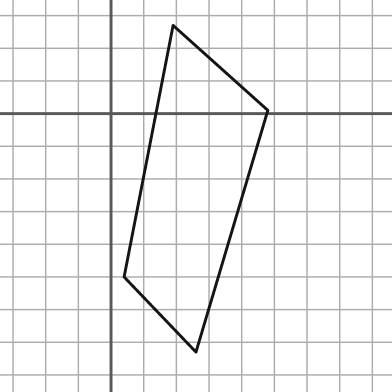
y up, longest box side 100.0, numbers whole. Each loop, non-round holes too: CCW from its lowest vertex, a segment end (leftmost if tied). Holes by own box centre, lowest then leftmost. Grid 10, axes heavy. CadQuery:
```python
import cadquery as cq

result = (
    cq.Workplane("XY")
    .moveTo(26.0, -73.0)
    .lineTo(48.0, 1.0)
    .lineTo(19.0, 27.0)
    .lineTo(4.0, -50.0)
    .close()
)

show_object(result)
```